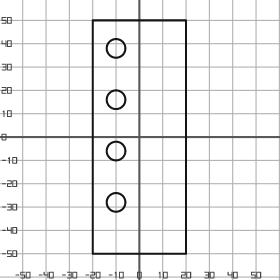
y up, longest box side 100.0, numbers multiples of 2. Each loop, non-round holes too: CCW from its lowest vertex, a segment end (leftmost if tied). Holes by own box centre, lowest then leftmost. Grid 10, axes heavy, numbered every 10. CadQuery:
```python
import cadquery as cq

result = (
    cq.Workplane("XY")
    .moveTo(-20.0, -50.0)
    .lineTo(20.0, -50.0)
    .lineTo(20.0, 50.0)
    .lineTo(-20.0, 50.0)
    .close()
    .moveTo(-10.0, -28.0)
    .circle(4.0)
    .moveTo(-10.0, -6.0)
    .circle(4.0)
    .moveTo(-10.0, 16.0)
    .circle(4.0)
    .moveTo(-10.0, 38.0)
    .circle(4.0)
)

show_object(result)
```